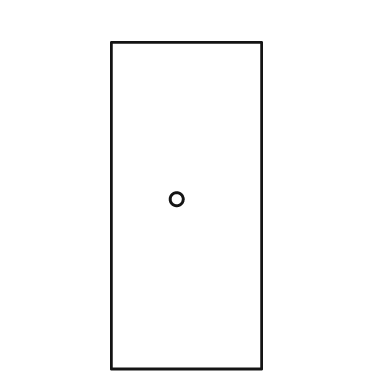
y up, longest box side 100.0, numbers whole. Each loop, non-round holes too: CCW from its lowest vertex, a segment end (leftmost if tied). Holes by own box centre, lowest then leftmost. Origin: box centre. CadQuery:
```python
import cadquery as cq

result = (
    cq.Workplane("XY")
    .moveTo(-23.0, -50.0)
    .lineTo(23.0, -50.0)
    .lineTo(23.0, 50.0)
    .lineTo(-23.0, 50.0)
    .close()
    .moveTo(-3.0, 2.0)
    .circle(2.0)
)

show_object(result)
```